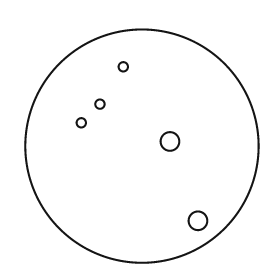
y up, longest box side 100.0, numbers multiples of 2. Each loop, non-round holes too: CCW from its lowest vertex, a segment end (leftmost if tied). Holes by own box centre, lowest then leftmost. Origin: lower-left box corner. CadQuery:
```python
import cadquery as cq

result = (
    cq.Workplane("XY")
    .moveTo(50.0, 50.0)
    .circle(50.0)
    .moveTo(74.0, 18.0)
    .circle(4.0)
    .moveTo(62.0, 52.0)
    .circle(4.0)
    .moveTo(24.0, 60.0)
    .circle(2.0)
    .moveTo(32.0, 68.0)
    .circle(2.0)
    .moveTo(42.0, 84.0)
    .circle(2.0)
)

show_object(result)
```